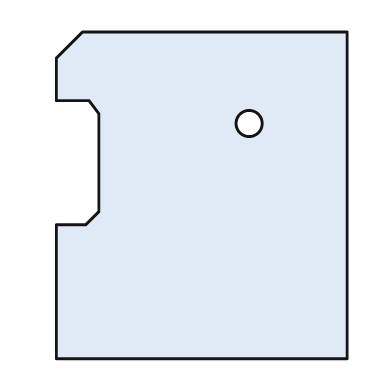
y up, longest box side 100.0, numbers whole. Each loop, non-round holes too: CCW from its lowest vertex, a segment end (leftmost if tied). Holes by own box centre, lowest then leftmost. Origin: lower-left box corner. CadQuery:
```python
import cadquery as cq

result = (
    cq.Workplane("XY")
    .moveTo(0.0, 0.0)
    .lineTo(89.0, 0.0)
    .lineTo(89.0, 100.0)
    .lineTo(8.0, 100.0)
    .lineTo(0.0, 92.0)
    .lineTo(0.0, 79.0)
    .lineTo(10.0, 79.0)
    .lineTo(13.0, 75.0)
    .lineTo(13.0, 45.0)
    .lineTo(9.0, 41.0)
    .lineTo(0.0, 41.0)
    .close()
    .moveTo(59.0, 72.0)
    .circle(4.0)
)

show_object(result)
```